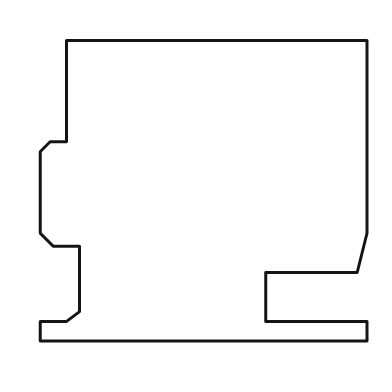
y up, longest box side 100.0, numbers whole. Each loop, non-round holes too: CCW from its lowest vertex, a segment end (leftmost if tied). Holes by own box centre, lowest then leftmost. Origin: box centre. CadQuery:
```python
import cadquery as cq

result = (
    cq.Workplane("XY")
    .moveTo(-50.0, -46.0)
    .lineTo(50.0, -46.0)
    .lineTo(50.0, -40.0)
    .lineTo(19.0, -40.0)
    .lineTo(19.0, -25.0)
    .lineTo(47.0, -25.0)
    .lineTo(50.0, -13.0)
    .lineTo(50.0, 46.0)
    .lineTo(-42.0, 46.0)
    .lineTo(-42.0, 15.0)
    .lineTo(-47.0, 15.0)
    .lineTo(-50.0, 12.0)
    .lineTo(-50.0, -13.0)
    .lineTo(-46.0, -17.0)
    .lineTo(-38.0, -17.0)
    .lineTo(-38.0, -37.0)
    .lineTo(-42.0, -40.0)
    .lineTo(-50.0, -40.0)
    .close()
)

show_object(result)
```